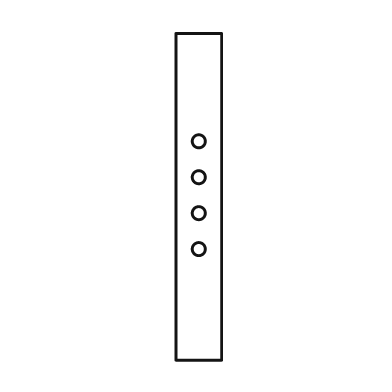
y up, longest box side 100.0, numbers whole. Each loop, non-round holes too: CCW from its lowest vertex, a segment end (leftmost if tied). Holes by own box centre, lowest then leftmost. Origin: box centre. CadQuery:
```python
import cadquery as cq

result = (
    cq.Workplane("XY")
    .moveTo(-7.0, -50.0)
    .lineTo(7.0, -50.0)
    .lineTo(7.0, 50.0)
    .lineTo(-7.0, 50.0)
    .close()
    .moveTo(0.0, -16.0)
    .circle(2.0)
    .moveTo(0.0, -5.0)
    .circle(2.0)
    .moveTo(0.0, 6.0)
    .circle(2.0)
    .moveTo(0.0, 17.0)
    .circle(2.0)
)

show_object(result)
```